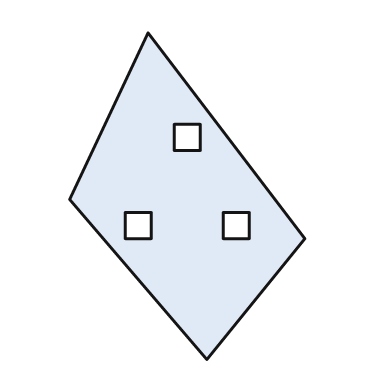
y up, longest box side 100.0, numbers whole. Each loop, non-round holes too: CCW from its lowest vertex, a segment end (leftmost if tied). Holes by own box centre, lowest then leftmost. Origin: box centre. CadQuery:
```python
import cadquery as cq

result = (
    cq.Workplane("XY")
    .moveTo(6.0, -50.0)
    .lineTo(36.0, -13.0)
    .lineTo(-12.0, 50.0)
    .lineTo(-36.0, -1.0)
    .close()
    .moveTo(-19.0, -13.0)
    .lineTo(-11.0, -13.0)
    .lineTo(-11.0, -5.0)
    .lineTo(-19.0, -5.0)
    .close()
    .moveTo(11.0, -13.0)
    .lineTo(19.0, -13.0)
    .lineTo(19.0, -5.0)
    .lineTo(11.0, -5.0)
    .close()
    .moveTo(-4.0, 14.0)
    .lineTo(4.0, 14.0)
    .lineTo(4.0, 22.0)
    .lineTo(-4.0, 22.0)
    .close()
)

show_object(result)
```